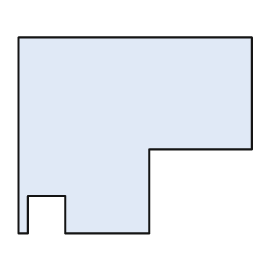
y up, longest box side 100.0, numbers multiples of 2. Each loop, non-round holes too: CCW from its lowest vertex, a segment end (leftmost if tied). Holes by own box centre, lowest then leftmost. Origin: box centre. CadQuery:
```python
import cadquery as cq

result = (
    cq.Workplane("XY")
    .moveTo(-50.0, -42.0)
    .lineTo(-46.0, -42.0)
    .lineTo(-46.0, -26.0)
    .lineTo(-30.0, -26.0)
    .lineTo(-30.0, -42.0)
    .lineTo(6.0, -42.0)
    .lineTo(6.0, -6.0)
    .lineTo(50.0, -6.0)
    .lineTo(50.0, 42.0)
    .lineTo(-50.0, 42.0)
    .close()
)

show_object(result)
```